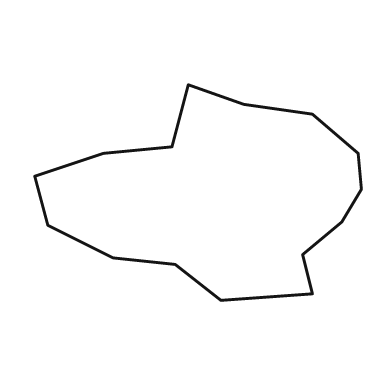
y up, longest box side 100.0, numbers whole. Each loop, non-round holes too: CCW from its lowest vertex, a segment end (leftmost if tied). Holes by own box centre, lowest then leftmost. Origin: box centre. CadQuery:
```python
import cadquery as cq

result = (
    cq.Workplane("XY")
    .moveTo(7.0, -33.0)
    .lineTo(35.0, -31.0)
    .lineTo(32.0, -19.0)
    .lineTo(44.0, -9.0)
    .lineTo(50.0, 1.0)
    .lineTo(49.0, 12.0)
    .lineTo(35.0, 24.0)
    .lineTo(14.0, 27.0)
    .lineTo(-3.0, 33.0)
    .lineTo(-8.0, 14.0)
    .lineTo(-29.0, 12.0)
    .lineTo(-50.0, 5.0)
    .lineTo(-46.0, -10.0)
    .lineTo(-26.0, -20.0)
    .lineTo(-7.0, -22.0)
    .close()
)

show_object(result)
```